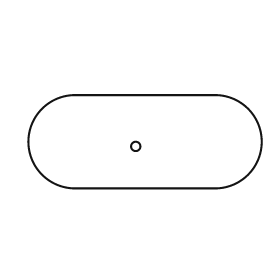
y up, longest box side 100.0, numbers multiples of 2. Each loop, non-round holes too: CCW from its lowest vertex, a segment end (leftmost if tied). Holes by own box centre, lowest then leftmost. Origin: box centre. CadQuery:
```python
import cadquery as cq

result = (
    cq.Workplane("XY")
    .moveTo(-30.0, -20.0)
    .lineTo(30.0, -20.0)
    .threePointArc((50.0, 0.0), (30.0, 20.0))
    .lineTo(-30.0, 20.0)
    .threePointArc((-50.0, 0.0), (-30.0, -20.0))
    .close()
    .moveTo(-4.0, -2.0)
    .circle(2.0)
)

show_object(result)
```